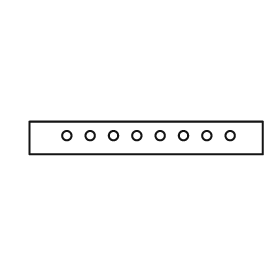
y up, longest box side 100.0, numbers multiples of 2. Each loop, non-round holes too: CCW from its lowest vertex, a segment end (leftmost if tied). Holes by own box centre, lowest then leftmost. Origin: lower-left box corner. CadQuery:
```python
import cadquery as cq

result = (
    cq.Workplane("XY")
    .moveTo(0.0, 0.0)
    .lineTo(100.0, 0.0)
    .lineTo(100.0, 14.0)
    .lineTo(0.0, 14.0)
    .close()
    .moveTo(16.0, 8.0)
    .circle(2.0)
    .moveTo(26.0, 8.0)
    .circle(2.0)
    .moveTo(36.0, 8.0)
    .circle(2.0)
    .moveTo(46.0, 8.0)
    .circle(2.0)
    .moveTo(56.0, 8.0)
    .circle(2.0)
    .moveTo(66.0, 8.0)
    .circle(2.0)
    .moveTo(76.0, 8.0)
    .circle(2.0)
    .moveTo(86.0, 8.0)
    .circle(2.0)
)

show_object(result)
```